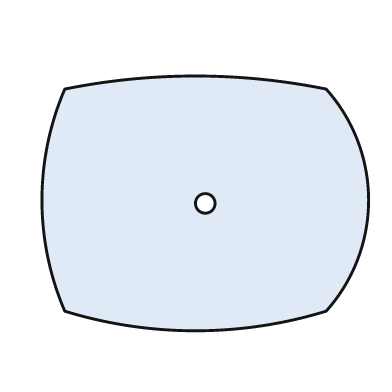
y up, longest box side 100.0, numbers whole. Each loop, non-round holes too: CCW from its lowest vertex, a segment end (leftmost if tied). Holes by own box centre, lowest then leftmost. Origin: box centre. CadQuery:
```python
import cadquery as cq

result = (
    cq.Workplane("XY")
    .moveTo(-43.0, -33.0)
    .threePointArc((-3.0, -39.0), (37.0, -33.0))
    .threePointArc((50.0, 1.0), (37.0, 35.0))
    .threePointArc((-3.0, 39.0), (-43.0, 35.0))
    .threePointArc((-50.0, 1.0), (-43.0, -33.0))
    .close()
    .moveTo(0.0, 0.0)
    .circle(3.0)
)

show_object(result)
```